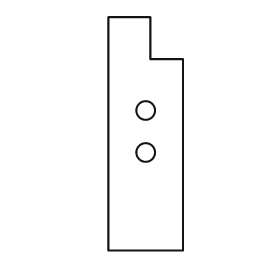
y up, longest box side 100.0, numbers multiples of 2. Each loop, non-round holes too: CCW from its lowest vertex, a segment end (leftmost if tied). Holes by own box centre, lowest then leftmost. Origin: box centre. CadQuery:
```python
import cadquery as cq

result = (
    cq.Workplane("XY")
    .moveTo(-16.0, -50.0)
    .lineTo(16.0, -50.0)
    .lineTo(16.0, 32.0)
    .lineTo(2.0, 32.0)
    .lineTo(2.0, 50.0)
    .lineTo(-16.0, 50.0)
    .close()
    .moveTo(0.0, -8.0)
    .circle(4.0)
    .moveTo(0.0, 10.0)
    .circle(4.0)
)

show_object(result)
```